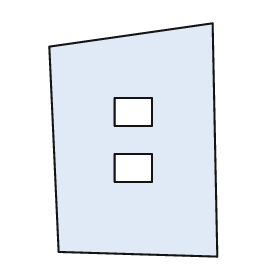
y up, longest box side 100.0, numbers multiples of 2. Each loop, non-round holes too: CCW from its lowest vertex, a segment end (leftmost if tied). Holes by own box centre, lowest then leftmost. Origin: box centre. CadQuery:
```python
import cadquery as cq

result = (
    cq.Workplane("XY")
    .moveTo(36.0, -50.0)
    .lineTo(34.0, 50.0)
    .lineTo(-36.0, 40.0)
    .lineTo(-32.0, -48.0)
    .close()
    .moveTo(-8.0, -18.0)
    .lineTo(8.0, -18.0)
    .lineTo(8.0, -6.0)
    .lineTo(-8.0, -6.0)
    .close()
    .moveTo(-8.0, 6.0)
    .lineTo(8.0, 6.0)
    .lineTo(8.0, 18.0)
    .lineTo(-8.0, 18.0)
    .close()
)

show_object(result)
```